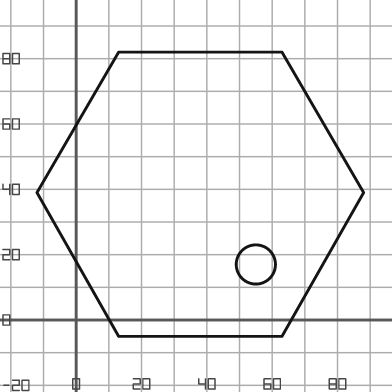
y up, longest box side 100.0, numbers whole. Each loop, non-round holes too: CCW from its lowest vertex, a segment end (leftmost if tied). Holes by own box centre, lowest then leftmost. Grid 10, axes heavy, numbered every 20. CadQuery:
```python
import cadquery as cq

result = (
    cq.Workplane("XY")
    .moveTo(13.0, -5.0)
    .lineTo(63.0, -5.0)
    .lineTo(88.0, 39.0)
    .lineTo(63.0, 82.0)
    .lineTo(13.0, 82.0)
    .lineTo(-12.0, 39.0)
    .close()
    .moveTo(55.0, 17.0)
    .circle(6.0)
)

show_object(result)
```